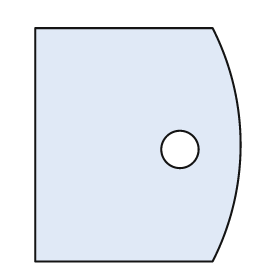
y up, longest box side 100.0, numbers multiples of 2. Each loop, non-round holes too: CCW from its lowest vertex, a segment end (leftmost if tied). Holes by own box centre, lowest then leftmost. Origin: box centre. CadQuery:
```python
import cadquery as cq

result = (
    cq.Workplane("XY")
    .moveTo(-44.0, -50.0)
    .lineTo(32.0, -50.0)
    .threePointArc((44.0, 0.0), (32.0, 50.0))
    .lineTo(-44.0, 50.0)
    .close()
    .moveTo(18.0, -2.0)
    .circle(8.0)
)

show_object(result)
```